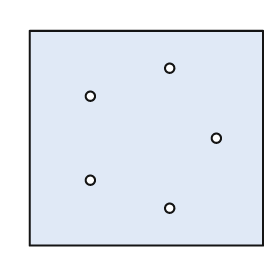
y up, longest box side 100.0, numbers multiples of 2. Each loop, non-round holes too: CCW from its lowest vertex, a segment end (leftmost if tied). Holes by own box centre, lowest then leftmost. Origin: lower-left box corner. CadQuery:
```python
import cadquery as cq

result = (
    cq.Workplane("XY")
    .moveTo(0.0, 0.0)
    .lineTo(100.0, 0.0)
    .lineTo(100.0, 92.0)
    .lineTo(0.0, 92.0)
    .close()
    .moveTo(60.0, 16.0)
    .circle(2.0)
    .moveTo(26.0, 28.0)
    .circle(2.0)
    .moveTo(80.0, 46.0)
    .circle(2.0)
    .moveTo(26.0, 64.0)
    .circle(2.0)
    .moveTo(60.0, 76.0)
    .circle(2.0)
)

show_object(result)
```